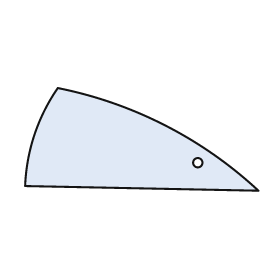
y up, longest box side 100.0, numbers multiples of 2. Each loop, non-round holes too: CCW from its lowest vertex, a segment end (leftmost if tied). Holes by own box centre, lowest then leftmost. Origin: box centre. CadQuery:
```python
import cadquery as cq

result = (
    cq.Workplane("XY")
    .moveTo(50.0, -22.0)
    .threePointArc((10.0, 6.0), (-36.0, 22.0))
    .threePointArc((-46.0, 2.0), (-50.0, -20.0))
    .close()
    .moveTo(24.0, -10.0)
    .circle(2.0)
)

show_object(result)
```